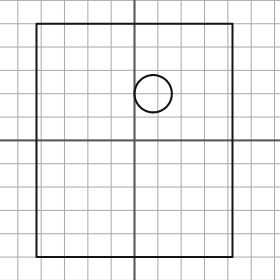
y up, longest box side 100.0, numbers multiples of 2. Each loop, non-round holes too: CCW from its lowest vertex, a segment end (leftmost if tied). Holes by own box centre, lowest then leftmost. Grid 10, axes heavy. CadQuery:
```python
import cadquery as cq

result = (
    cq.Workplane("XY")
    .moveTo(-42.0, -50.0)
    .lineTo(42.0, -50.0)
    .lineTo(42.0, 50.0)
    .lineTo(-42.0, 50.0)
    .close()
    .moveTo(8.0, 20.0)
    .circle(8.0)
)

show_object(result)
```